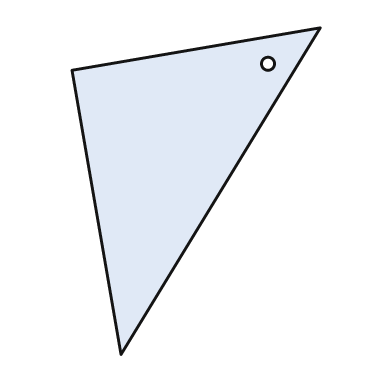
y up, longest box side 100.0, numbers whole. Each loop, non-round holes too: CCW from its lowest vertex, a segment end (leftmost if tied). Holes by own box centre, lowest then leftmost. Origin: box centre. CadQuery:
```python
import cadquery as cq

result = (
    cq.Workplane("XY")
    .moveTo(-23.0, -50.0)
    .lineTo(38.0, 50.0)
    .lineTo(-38.0, 37.0)
    .close()
    .moveTo(22.0, 39.0)
    .circle(2.0)
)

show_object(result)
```